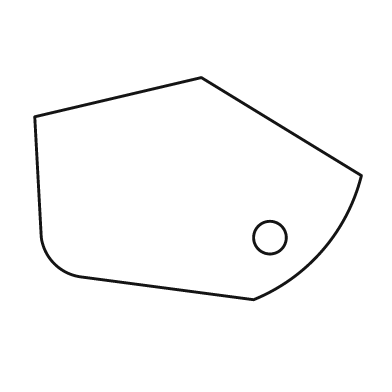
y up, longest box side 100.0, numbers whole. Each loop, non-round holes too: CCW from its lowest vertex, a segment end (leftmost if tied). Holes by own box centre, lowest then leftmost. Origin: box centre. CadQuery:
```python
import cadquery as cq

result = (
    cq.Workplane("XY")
    .moveTo(17.0, -34.0)
    .threePointArc((38.0, -19.0), (50.0, 4.0))
    .lineTo(1.0, 34.0)
    .lineTo(-50.0, 22.0)
    .lineTo(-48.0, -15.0)
    .threePointArc((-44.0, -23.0), (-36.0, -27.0))
    .close()
    .moveTo(22.0, -15.0)
    .circle(5.0)
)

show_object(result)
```